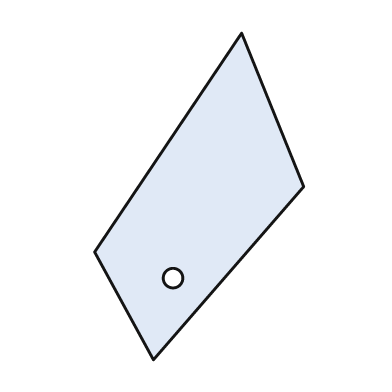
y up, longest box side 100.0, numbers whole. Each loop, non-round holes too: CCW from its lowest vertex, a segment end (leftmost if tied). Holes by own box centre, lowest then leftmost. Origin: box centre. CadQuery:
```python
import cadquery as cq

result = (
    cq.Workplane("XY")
    .moveTo(-14.0, -50.0)
    .lineTo(32.0, 3.0)
    .lineTo(13.0, 50.0)
    .lineTo(-32.0, -17.0)
    .close()
    .moveTo(-8.0, -25.0)
    .circle(3.0)
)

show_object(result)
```